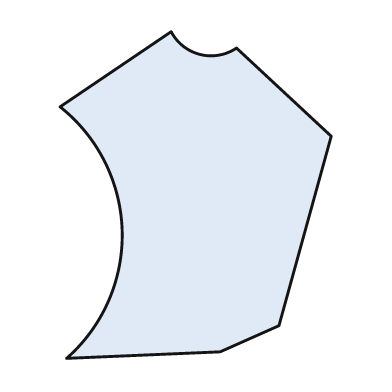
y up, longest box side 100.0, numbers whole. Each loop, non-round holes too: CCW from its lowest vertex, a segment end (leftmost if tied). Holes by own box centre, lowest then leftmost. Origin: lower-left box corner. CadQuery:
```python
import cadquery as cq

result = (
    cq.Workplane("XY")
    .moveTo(2.0, 0.0)
    .lineTo(49.0, 2.0)
    .lineTo(67.0, 10.0)
    .lineTo(83.0, 68.0)
    .lineTo(54.0, 95.0)
    .threePointArc((43.0, 93.0), (34.0, 100.0))
    .lineTo(0.0, 77.0)
    .threePointArc((19.0, 39.0), (2.0, 0.0))
    .close()
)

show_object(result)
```